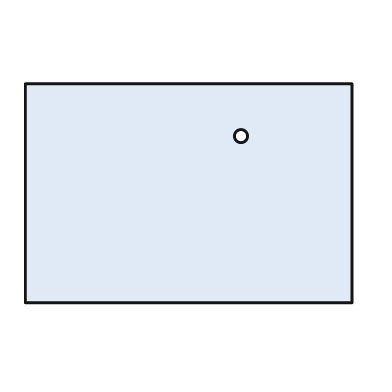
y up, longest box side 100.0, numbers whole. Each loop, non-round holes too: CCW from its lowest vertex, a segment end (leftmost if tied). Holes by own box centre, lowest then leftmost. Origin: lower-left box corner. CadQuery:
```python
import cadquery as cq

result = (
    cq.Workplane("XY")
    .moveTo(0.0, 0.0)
    .lineTo(100.0, 0.0)
    .lineTo(100.0, 67.0)
    .lineTo(0.0, 67.0)
    .close()
    .moveTo(66.0, 51.0)
    .circle(2.0)
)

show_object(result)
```